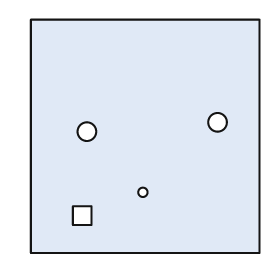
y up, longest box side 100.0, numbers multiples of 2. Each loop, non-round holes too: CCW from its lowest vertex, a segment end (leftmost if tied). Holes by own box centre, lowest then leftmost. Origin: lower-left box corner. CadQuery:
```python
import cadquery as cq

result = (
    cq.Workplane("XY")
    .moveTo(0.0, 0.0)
    .lineTo(98.0, 0.0)
    .lineTo(98.0, 100.0)
    .lineTo(0.0, 100.0)
    .close()
    .moveTo(18.0, 12.0)
    .lineTo(26.0, 12.0)
    .lineTo(26.0, 20.0)
    .lineTo(18.0, 20.0)
    .close()
    .moveTo(48.0, 26.0)
    .circle(2.0)
    .moveTo(24.0, 52.0)
    .circle(4.0)
    .moveTo(80.0, 56.0)
    .circle(4.0)
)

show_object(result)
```